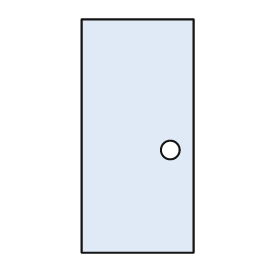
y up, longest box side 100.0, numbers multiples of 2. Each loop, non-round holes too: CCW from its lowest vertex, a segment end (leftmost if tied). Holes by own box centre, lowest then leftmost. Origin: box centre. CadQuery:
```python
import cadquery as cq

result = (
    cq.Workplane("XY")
    .moveTo(-24.0, -50.0)
    .lineTo(24.0, -50.0)
    .lineTo(24.0, 50.0)
    .lineTo(-24.0, 50.0)
    .close()
    .moveTo(14.0, -6.0)
    .circle(4.0)
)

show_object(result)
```